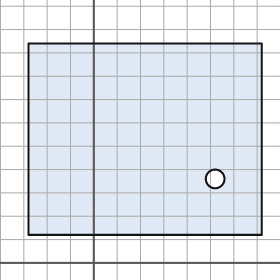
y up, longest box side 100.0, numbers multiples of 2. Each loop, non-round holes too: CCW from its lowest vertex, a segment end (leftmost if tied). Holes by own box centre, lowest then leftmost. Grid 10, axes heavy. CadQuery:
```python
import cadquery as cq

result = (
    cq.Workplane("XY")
    .moveTo(-28.0, 12.0)
    .lineTo(72.0, 12.0)
    .lineTo(72.0, 94.0)
    .lineTo(-28.0, 94.0)
    .close()
    .moveTo(52.0, 36.0)
    .circle(4.0)
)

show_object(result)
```